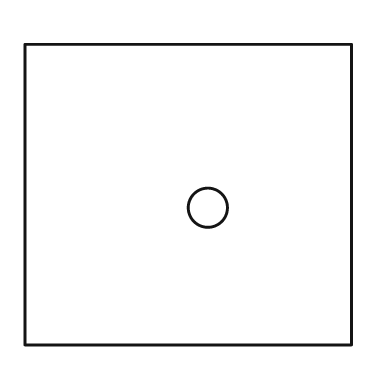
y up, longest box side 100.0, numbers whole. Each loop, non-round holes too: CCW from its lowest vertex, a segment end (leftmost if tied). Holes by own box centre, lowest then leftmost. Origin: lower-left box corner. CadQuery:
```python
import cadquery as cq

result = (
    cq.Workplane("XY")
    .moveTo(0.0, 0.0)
    .lineTo(100.0, 0.0)
    .lineTo(100.0, 92.0)
    .lineTo(0.0, 92.0)
    .close()
    .moveTo(56.0, 42.0)
    .circle(6.0)
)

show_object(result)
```